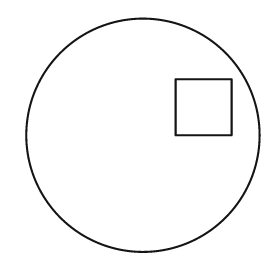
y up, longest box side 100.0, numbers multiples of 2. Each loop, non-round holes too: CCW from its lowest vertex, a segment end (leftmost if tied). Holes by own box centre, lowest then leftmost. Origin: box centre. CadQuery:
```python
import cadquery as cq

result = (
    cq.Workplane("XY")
    .moveTo(0.0, 0.0)
    .circle(50.0)
    .moveTo(14.0, 0.0)
    .lineTo(38.0, 0.0)
    .lineTo(38.0, 24.0)
    .lineTo(14.0, 24.0)
    .close()
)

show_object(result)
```